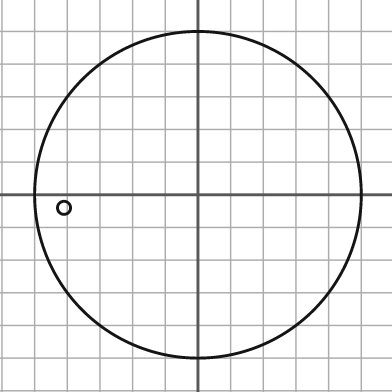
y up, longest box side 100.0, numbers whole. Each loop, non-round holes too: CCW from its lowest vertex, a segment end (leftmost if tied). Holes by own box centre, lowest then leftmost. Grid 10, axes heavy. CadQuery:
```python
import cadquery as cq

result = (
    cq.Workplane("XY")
    .moveTo(0.0, 0.0)
    .circle(50.0)
    .moveTo(-41.0, -4.0)
    .circle(2.0)
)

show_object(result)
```